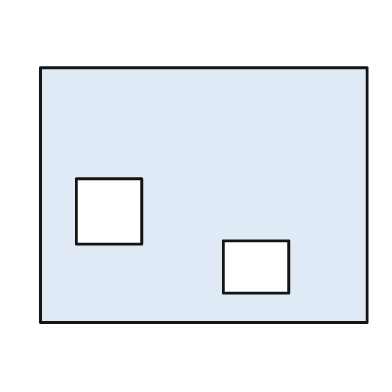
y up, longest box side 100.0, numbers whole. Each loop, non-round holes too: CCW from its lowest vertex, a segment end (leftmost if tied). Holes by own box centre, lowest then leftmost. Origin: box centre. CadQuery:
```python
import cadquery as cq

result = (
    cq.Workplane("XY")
    .moveTo(-50.0, -39.0)
    .lineTo(50.0, -39.0)
    .lineTo(50.0, 39.0)
    .lineTo(-50.0, 39.0)
    .close()
    .moveTo(6.0, -30.0)
    .lineTo(26.0, -30.0)
    .lineTo(26.0, -14.0)
    .lineTo(6.0, -14.0)
    .close()
    .moveTo(-39.0, -15.0)
    .lineTo(-19.0, -15.0)
    .lineTo(-19.0, 5.0)
    .lineTo(-39.0, 5.0)
    .close()
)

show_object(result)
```